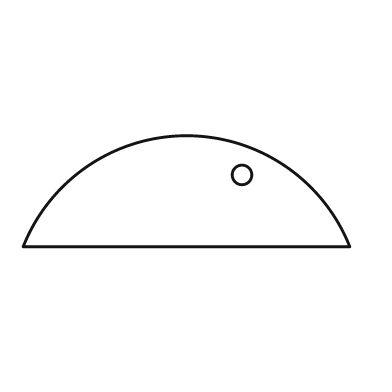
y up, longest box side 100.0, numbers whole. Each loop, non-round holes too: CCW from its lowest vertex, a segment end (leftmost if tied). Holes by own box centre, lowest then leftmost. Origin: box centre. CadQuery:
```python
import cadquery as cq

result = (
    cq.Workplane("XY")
    .moveTo(-50.0, -17.0)
    .lineTo(50.0, -17.0)
    .threePointArc((0.0, 17.0), (-50.0, -17.0))
    .close()
    .moveTo(17.0, 5.0)
    .circle(3.0)
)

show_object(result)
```